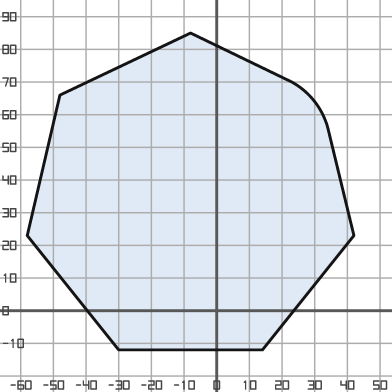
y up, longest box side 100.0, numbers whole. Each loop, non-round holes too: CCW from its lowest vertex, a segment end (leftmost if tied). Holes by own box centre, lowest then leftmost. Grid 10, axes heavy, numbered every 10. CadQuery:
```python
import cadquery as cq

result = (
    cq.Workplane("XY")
    .moveTo(-30.0, -12.0)
    .lineTo(14.0, -12.0)
    .lineTo(42.0, 23.0)
    .lineTo(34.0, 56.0)
    .threePointArc((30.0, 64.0), (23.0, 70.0))
    .lineTo(-8.0, 85.0)
    .lineTo(-48.0, 66.0)
    .lineTo(-58.0, 23.0)
    .close()
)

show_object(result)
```